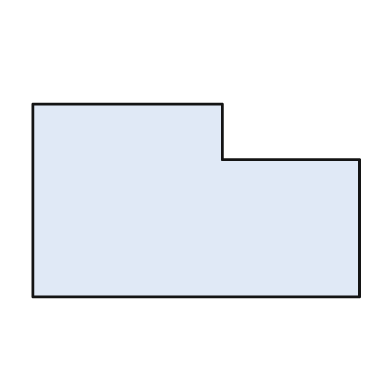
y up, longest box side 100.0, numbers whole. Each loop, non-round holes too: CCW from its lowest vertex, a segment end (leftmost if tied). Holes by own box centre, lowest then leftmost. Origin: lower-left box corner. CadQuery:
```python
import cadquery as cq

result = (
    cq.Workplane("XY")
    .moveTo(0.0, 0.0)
    .lineTo(100.0, 0.0)
    .lineTo(100.0, 42.0)
    .lineTo(58.0, 42.0)
    .lineTo(58.0, 59.0)
    .lineTo(0.0, 59.0)
    .close()
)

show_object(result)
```